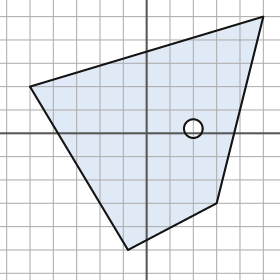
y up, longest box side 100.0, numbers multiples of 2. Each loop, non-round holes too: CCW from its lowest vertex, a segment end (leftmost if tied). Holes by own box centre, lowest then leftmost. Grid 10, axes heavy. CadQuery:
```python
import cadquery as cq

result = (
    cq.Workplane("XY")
    .moveTo(-8.0, -50.0)
    .lineTo(30.0, -30.0)
    .lineTo(50.0, 50.0)
    .lineTo(-50.0, 20.0)
    .close()
    .moveTo(20.0, 2.0)
    .circle(4.0)
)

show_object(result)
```